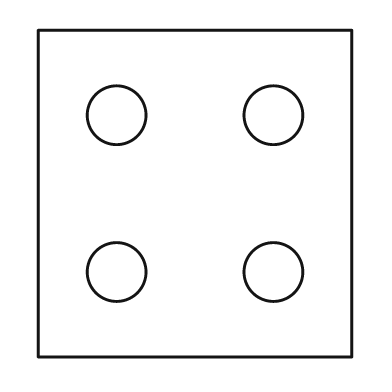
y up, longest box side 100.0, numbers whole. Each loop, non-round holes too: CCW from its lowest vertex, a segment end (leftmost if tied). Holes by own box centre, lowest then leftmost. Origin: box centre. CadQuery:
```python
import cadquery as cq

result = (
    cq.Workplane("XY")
    .moveTo(-48.0, -50.0)
    .lineTo(48.0, -50.0)
    .lineTo(48.0, 50.0)
    .lineTo(-48.0, 50.0)
    .close()
    .moveTo(-24.0, -24.0)
    .circle(9.0)
    .moveTo(24.0, -24.0)
    .circle(9.0)
    .moveTo(-24.0, 24.0)
    .circle(9.0)
    .moveTo(24.0, 24.0)
    .circle(9.0)
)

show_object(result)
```